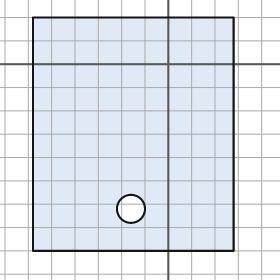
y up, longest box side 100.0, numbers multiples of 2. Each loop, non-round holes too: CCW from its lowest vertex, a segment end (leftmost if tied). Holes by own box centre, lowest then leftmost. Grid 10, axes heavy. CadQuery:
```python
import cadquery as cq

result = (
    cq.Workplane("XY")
    .moveTo(-58.0, -80.0)
    .lineTo(28.0, -80.0)
    .lineTo(28.0, 20.0)
    .lineTo(-58.0, 20.0)
    .close()
    .moveTo(-16.0, -62.0)
    .circle(6.0)
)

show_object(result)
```